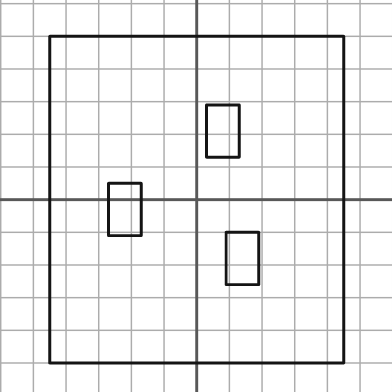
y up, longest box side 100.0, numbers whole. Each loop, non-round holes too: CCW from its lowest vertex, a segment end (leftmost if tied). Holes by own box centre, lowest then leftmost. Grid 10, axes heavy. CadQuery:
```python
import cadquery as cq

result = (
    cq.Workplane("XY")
    .moveTo(-45.0, -50.0)
    .lineTo(45.0, -50.0)
    .lineTo(45.0, 50.0)
    .lineTo(-45.0, 50.0)
    .close()
    .moveTo(9.0, -26.0)
    .lineTo(19.0, -26.0)
    .lineTo(19.0, -10.0)
    .lineTo(9.0, -10.0)
    .close()
    .moveTo(-27.0, -11.0)
    .lineTo(-17.0, -11.0)
    .lineTo(-17.0, 5.0)
    .lineTo(-27.0, 5.0)
    .close()
    .moveTo(3.0, 13.0)
    .lineTo(13.0, 13.0)
    .lineTo(13.0, 29.0)
    .lineTo(3.0, 29.0)
    .close()
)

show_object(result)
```